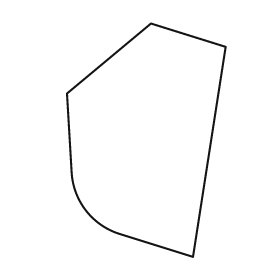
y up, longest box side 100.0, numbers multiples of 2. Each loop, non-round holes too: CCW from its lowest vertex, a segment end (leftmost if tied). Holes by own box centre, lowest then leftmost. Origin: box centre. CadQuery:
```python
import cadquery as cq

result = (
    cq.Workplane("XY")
    .moveTo(20.0, -50.0)
    .lineTo(34.0, 40.0)
    .lineTo(2.0, 50.0)
    .lineTo(-34.0, 20.0)
    .lineTo(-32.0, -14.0)
    .threePointArc((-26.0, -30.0), (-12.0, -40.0))
    .close()
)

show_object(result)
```